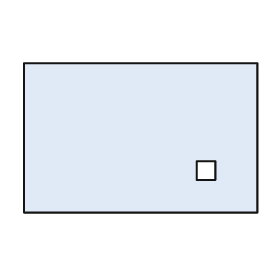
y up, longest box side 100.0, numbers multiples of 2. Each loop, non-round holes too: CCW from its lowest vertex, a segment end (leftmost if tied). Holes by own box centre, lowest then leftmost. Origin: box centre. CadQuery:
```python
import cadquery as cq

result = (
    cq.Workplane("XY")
    .moveTo(-50.0, -32.0)
    .lineTo(50.0, -32.0)
    .lineTo(50.0, 32.0)
    .lineTo(-50.0, 32.0)
    .close()
    .moveTo(24.0, -18.0)
    .lineTo(32.0, -18.0)
    .lineTo(32.0, -10.0)
    .lineTo(24.0, -10.0)
    .close()
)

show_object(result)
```